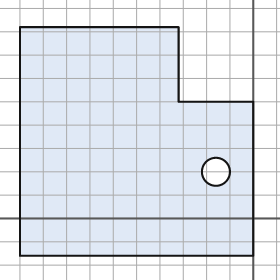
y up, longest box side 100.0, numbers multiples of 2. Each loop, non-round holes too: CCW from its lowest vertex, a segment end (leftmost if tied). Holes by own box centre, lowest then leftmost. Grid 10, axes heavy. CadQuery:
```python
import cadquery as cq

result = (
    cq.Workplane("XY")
    .moveTo(-100.0, -16.0)
    .lineTo(0.0, -16.0)
    .lineTo(0.0, 50.0)
    .lineTo(-32.0, 50.0)
    .lineTo(-32.0, 82.0)
    .lineTo(-100.0, 82.0)
    .close()
    .moveTo(-16.0, 20.0)
    .circle(6.0)
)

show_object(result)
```